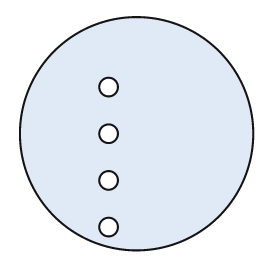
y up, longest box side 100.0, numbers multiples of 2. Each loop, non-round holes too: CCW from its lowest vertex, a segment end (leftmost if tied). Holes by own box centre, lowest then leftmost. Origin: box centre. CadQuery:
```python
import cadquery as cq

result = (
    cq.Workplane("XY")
    .moveTo(0.0, 0.0)
    .circle(50.0)
    .moveTo(-12.0, -40.0)
    .circle(4.0)
    .moveTo(-12.0, -20.0)
    .circle(4.0)
    .moveTo(-12.0, 0.0)
    .circle(4.0)
    .moveTo(-12.0, 20.0)
    .circle(4.0)
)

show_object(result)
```